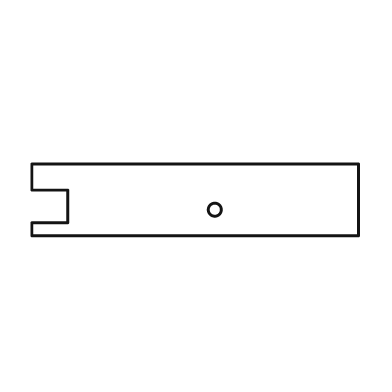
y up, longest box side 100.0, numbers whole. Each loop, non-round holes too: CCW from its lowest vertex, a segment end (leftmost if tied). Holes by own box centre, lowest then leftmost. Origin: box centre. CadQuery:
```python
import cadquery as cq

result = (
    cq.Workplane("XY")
    .moveTo(-50.0, -11.0)
    .lineTo(50.0, -11.0)
    .lineTo(50.0, 11.0)
    .lineTo(-50.0, 11.0)
    .lineTo(-50.0, 3.0)
    .lineTo(-39.0, 3.0)
    .lineTo(-39.0, -7.0)
    .lineTo(-50.0, -7.0)
    .close()
    .moveTo(6.0, -3.0)
    .circle(2.0)
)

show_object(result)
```